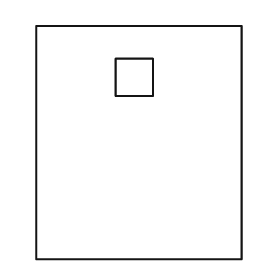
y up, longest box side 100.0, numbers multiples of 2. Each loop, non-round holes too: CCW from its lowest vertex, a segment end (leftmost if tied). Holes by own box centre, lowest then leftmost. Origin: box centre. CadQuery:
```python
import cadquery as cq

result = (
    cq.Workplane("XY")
    .moveTo(-44.0, -50.0)
    .lineTo(44.0, -50.0)
    .lineTo(44.0, 50.0)
    .lineTo(-44.0, 50.0)
    .close()
    .moveTo(-10.0, 20.0)
    .lineTo(6.0, 20.0)
    .lineTo(6.0, 36.0)
    .lineTo(-10.0, 36.0)
    .close()
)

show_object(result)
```